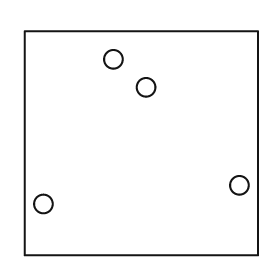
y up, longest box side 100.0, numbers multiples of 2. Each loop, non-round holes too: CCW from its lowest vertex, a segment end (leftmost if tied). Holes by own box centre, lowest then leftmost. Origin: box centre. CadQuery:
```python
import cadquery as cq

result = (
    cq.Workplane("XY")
    .moveTo(-50.0, -48.0)
    .lineTo(50.0, -48.0)
    .lineTo(50.0, 48.0)
    .lineTo(-50.0, 48.0)
    .close()
    .moveTo(-42.0, -26.0)
    .circle(4.0)
    .moveTo(42.0, -18.0)
    .circle(4.0)
    .moveTo(2.0, 24.0)
    .circle(4.0)
    .moveTo(-12.0, 36.0)
    .circle(4.0)
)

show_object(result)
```